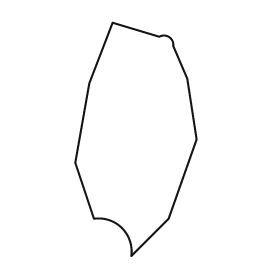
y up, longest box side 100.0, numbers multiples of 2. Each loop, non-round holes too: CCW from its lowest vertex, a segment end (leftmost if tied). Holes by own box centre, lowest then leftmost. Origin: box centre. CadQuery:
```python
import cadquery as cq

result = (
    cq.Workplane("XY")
    .moveTo(-2.0, -50.0)
    .lineTo(14.0, -34.0)
    .lineTo(26.0, 0.0)
    .lineTo(22.0, 26.0)
    .lineTo(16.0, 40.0)
    .threePointArc((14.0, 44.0), (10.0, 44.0))
    .lineTo(-10.0, 50.0)
    .lineTo(-20.0, 24.0)
    .lineTo(-26.0, -10.0)
    .lineTo(-18.0, -34.0)
    .threePointArc((-6.0, -38.0), (-2.0, -50.0))
    .close()
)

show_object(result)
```